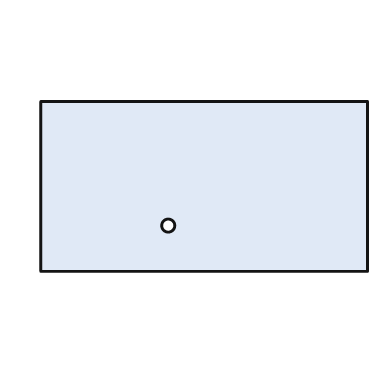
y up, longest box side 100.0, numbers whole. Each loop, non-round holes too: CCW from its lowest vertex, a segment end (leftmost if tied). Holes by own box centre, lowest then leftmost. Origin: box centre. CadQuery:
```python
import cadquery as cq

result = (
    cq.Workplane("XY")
    .moveTo(-50.0, -26.0)
    .lineTo(50.0, -26.0)
    .lineTo(50.0, 26.0)
    .lineTo(-50.0, 26.0)
    .close()
    .moveTo(-11.0, -12.0)
    .circle(2.0)
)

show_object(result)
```